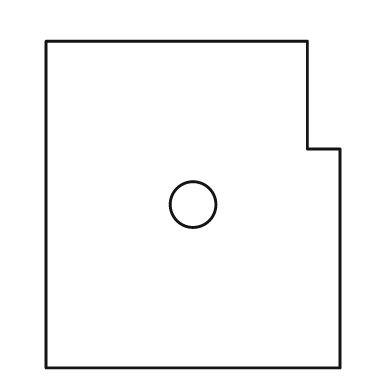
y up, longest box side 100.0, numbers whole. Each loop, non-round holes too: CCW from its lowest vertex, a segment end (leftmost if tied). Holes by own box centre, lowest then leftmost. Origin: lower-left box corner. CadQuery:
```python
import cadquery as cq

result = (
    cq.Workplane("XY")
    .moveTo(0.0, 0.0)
    .lineTo(90.0, 0.0)
    .lineTo(90.0, 67.0)
    .lineTo(80.0, 67.0)
    .lineTo(80.0, 100.0)
    .lineTo(0.0, 100.0)
    .close()
    .moveTo(45.0, 50.0)
    .circle(7.0)
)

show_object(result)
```